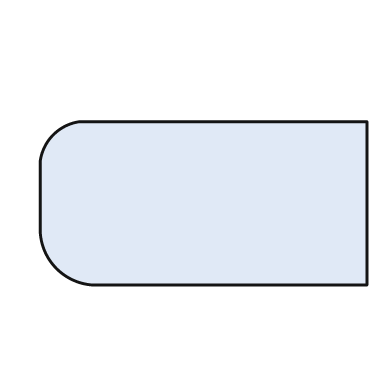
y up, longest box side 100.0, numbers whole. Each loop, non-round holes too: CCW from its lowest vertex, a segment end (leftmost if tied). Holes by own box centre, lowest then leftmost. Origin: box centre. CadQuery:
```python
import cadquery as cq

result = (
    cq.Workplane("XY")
    .moveTo(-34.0, -25.0)
    .lineTo(50.0, -25.0)
    .lineTo(50.0, 25.0)
    .lineTo(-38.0, 25.0)
    .threePointArc((-46.0, 21.0), (-50.0, 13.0))
    .lineTo(-50.0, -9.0)
    .threePointArc((-45.0, -20.0), (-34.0, -25.0))
    .close()
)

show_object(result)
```